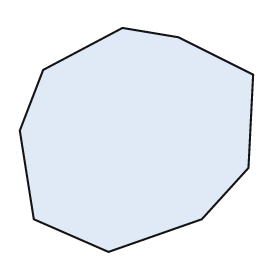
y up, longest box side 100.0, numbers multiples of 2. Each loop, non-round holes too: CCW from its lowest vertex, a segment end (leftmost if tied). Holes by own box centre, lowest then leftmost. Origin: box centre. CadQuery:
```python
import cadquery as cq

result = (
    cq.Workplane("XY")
    .moveTo(-12.0, -48.0)
    .lineTo(28.0, -34.0)
    .lineTo(48.0, -12.0)
    .lineTo(50.0, 28.0)
    .lineTo(18.0, 44.0)
    .lineTo(-6.0, 48.0)
    .lineTo(-40.0, 30.0)
    .lineTo(-50.0, 4.0)
    .lineTo(-44.0, -34.0)
    .close()
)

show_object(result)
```